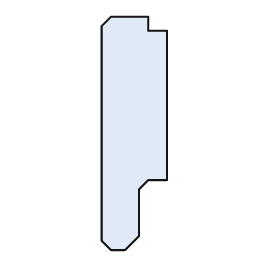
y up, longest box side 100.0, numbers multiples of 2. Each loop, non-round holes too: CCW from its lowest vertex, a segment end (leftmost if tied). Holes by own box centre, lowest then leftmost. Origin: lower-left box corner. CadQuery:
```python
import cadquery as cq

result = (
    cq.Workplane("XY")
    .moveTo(4.0, 0.0)
    .lineTo(10.0, 0.0)
    .lineTo(16.0, 6.0)
    .lineTo(16.0, 26.0)
    .lineTo(20.0, 30.0)
    .lineTo(28.0, 30.0)
    .lineTo(28.0, 94.0)
    .lineTo(20.0, 94.0)
    .lineTo(20.0, 100.0)
    .lineTo(4.0, 100.0)
    .lineTo(0.0, 96.0)
    .lineTo(0.0, 4.0)
    .close()
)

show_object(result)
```